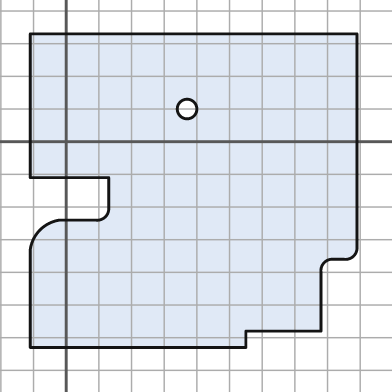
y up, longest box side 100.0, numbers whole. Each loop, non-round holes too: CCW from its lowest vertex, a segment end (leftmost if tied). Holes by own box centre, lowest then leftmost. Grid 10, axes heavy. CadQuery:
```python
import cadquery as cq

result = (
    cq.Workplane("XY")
    .moveTo(-11.0, -63.0)
    .lineTo(55.0, -63.0)
    .lineTo(55.0, -58.0)
    .lineTo(78.0, -58.0)
    .lineTo(78.0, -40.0)
    .threePointArc((79.0, -37.0), (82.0, -36.0))
    .lineTo(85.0, -36.0)
    .threePointArc((88.0, -35.0), (89.0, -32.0))
    .lineTo(89.0, 33.0)
    .lineTo(-11.0, 33.0)
    .lineTo(-11.0, -11.0)
    .lineTo(13.0, -11.0)
    .lineTo(13.0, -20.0)
    .threePointArc((12.0, -23.0), (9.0, -24.0))
    .lineTo(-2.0, -24.0)
    .threePointArc((-8.0, -27.0), (-11.0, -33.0))
    .close()
    .moveTo(37.0, 10.0)
    .circle(3.0)
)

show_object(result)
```